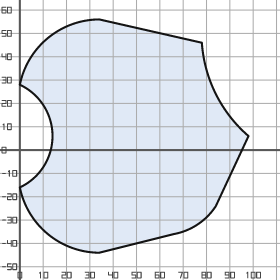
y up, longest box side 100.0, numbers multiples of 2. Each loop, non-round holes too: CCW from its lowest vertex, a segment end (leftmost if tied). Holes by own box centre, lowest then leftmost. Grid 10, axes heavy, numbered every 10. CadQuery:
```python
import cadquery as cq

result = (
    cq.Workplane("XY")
    .moveTo(34.0, -44.0)
    .lineTo(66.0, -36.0)
    .threePointArc((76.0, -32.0), (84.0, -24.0))
    .lineTo(98.0, 6.0)
    .threePointArc((84.0, 24.0), (78.0, 46.0))
    .lineTo(34.0, 56.0)
    .threePointArc((12.0, 48.0), (0.0, 28.0))
    .threePointArc((14.0, 6.0), (0.0, -16.0))
    .threePointArc((12.0, -36.0), (34.0, -44.0))
    .close()
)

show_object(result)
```